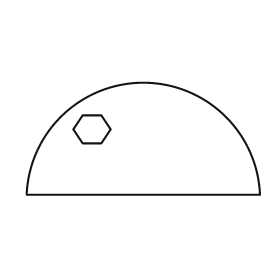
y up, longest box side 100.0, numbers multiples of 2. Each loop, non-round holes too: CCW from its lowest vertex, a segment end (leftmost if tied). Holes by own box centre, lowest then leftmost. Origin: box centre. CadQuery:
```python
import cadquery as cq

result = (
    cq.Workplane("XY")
    .moveTo(-50.0, -24.0)
    .lineTo(50.0, -24.0)
    .threePointArc((0.0, 24.0), (-50.0, -24.0))
    .close()
    .moveTo(-26.0, -2.0)
    .lineTo(-18.0, -2.0)
    .lineTo(-14.0, 4.0)
    .lineTo(-18.0, 10.0)
    .lineTo(-26.0, 10.0)
    .lineTo(-30.0, 4.0)
    .close()
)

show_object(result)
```